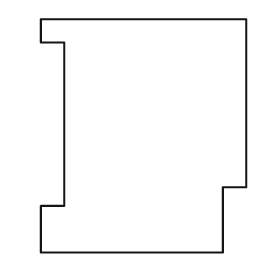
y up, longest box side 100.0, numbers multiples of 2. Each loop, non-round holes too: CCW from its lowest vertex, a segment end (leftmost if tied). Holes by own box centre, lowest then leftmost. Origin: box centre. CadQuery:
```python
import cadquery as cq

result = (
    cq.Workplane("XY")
    .moveTo(-44.0, -50.0)
    .lineTo(34.0, -50.0)
    .lineTo(34.0, -22.0)
    .lineTo(44.0, -22.0)
    .lineTo(44.0, 50.0)
    .lineTo(-44.0, 50.0)
    .lineTo(-44.0, 40.0)
    .lineTo(-34.0, 40.0)
    .lineTo(-34.0, -30.0)
    .lineTo(-44.0, -30.0)
    .close()
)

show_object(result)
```